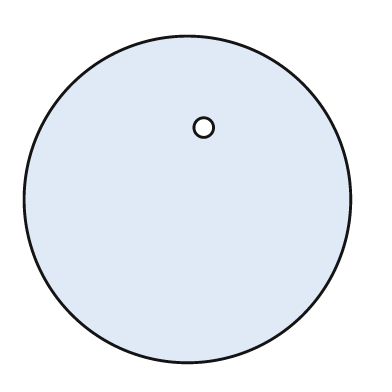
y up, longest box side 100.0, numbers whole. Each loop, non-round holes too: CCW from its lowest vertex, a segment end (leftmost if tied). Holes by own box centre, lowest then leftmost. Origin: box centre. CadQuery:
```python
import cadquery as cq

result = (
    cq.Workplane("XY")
    .moveTo(0.0, 0.0)
    .circle(50.0)
    .moveTo(5.0, 22.0)
    .circle(3.0)
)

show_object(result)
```